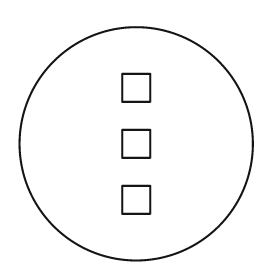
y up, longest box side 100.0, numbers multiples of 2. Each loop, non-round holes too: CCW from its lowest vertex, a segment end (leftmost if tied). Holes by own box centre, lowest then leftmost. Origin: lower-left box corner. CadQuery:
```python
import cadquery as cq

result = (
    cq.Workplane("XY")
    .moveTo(50.0, 50.0)
    .circle(50.0)
    .moveTo(44.0, 20.0)
    .lineTo(56.0, 20.0)
    .lineTo(56.0, 32.0)
    .lineTo(44.0, 32.0)
    .close()
    .moveTo(44.0, 44.0)
    .lineTo(56.0, 44.0)
    .lineTo(56.0, 56.0)
    .lineTo(44.0, 56.0)
    .close()
    .moveTo(44.0, 68.0)
    .lineTo(56.0, 68.0)
    .lineTo(56.0, 80.0)
    .lineTo(44.0, 80.0)
    .close()
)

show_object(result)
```